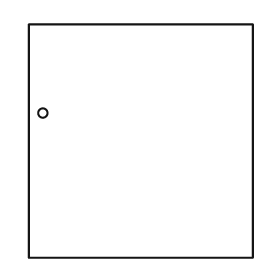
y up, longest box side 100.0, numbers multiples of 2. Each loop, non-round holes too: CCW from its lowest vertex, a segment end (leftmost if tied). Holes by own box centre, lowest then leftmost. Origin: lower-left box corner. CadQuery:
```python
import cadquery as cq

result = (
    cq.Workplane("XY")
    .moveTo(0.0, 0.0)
    .lineTo(96.0, 0.0)
    .lineTo(96.0, 100.0)
    .lineTo(0.0, 100.0)
    .close()
    .moveTo(6.0, 62.0)
    .circle(2.0)
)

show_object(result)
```